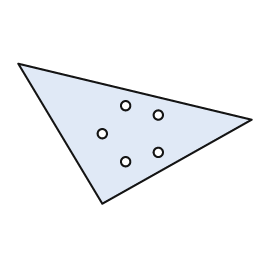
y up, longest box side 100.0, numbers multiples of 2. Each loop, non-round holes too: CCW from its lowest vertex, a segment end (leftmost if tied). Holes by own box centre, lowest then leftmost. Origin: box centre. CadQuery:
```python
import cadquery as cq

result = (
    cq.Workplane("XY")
    .moveTo(-14.0, -30.0)
    .lineTo(50.0, 6.0)
    .lineTo(-50.0, 30.0)
    .close()
    .moveTo(-4.0, -12.0)
    .circle(2.0)
    .moveTo(10.0, -8.0)
    .circle(2.0)
    .moveTo(-14.0, 0.0)
    .circle(2.0)
    .moveTo(10.0, 8.0)
    .circle(2.0)
    .moveTo(-4.0, 12.0)
    .circle(2.0)
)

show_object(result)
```